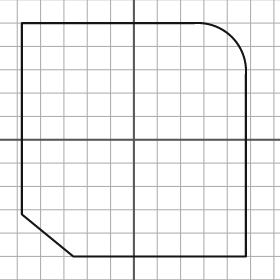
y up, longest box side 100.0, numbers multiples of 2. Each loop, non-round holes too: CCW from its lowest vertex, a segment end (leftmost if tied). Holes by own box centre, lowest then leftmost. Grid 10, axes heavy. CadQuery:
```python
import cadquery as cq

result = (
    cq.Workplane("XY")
    .moveTo(-26.0, -50.0)
    .lineTo(48.0, -50.0)
    .lineTo(48.0, 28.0)
    .threePointArc((42.0, 44.0), (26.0, 50.0))
    .lineTo(-48.0, 50.0)
    .lineTo(-48.0, -32.0)
    .close()
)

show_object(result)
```